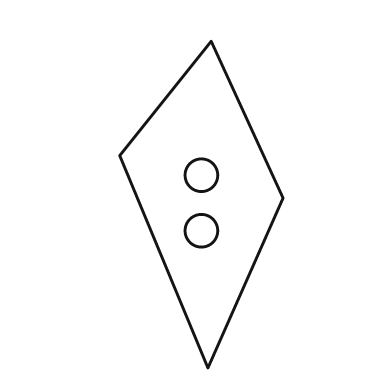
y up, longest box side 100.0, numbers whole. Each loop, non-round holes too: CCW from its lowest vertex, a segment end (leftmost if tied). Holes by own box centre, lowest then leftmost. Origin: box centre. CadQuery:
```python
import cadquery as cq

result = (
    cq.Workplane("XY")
    .moveTo(2.0, -50.0)
    .lineTo(25.0, 2.0)
    .lineTo(3.0, 50.0)
    .lineTo(-25.0, 15.0)
    .close()
    .moveTo(0.0, -8.0)
    .circle(5.0)
    .moveTo(0.0, 9.0)
    .circle(5.0)
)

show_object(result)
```